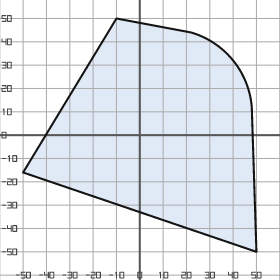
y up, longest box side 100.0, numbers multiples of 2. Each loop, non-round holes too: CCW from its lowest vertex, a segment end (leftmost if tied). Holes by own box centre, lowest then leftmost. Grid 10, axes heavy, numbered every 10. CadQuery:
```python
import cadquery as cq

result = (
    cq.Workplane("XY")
    .moveTo(50.0, -50.0)
    .lineTo(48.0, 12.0)
    .threePointArc((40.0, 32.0), (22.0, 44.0))
    .lineTo(-10.0, 50.0)
    .lineTo(-50.0, -16.0)
    .close()
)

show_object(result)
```